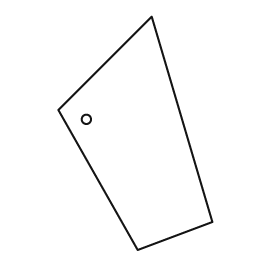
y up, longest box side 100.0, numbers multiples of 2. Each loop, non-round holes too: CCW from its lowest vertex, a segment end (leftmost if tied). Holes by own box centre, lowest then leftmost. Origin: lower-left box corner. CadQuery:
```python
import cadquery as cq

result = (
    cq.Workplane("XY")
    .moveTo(34.0, 0.0)
    .lineTo(66.0, 12.0)
    .lineTo(40.0, 100.0)
    .lineTo(0.0, 60.0)
    .close()
    .moveTo(12.0, 56.0)
    .circle(2.0)
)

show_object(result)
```